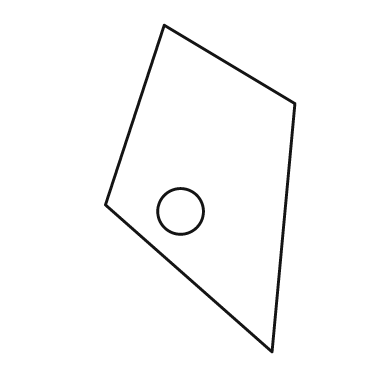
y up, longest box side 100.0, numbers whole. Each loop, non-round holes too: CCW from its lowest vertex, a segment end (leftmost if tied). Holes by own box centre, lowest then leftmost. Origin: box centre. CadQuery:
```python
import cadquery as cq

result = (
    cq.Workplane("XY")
    .moveTo(22.0, -50.0)
    .lineTo(29.0, 26.0)
    .lineTo(-11.0, 50.0)
    .lineTo(-29.0, -5.0)
    .close()
    .moveTo(-6.0, -7.0)
    .circle(7.0)
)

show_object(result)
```